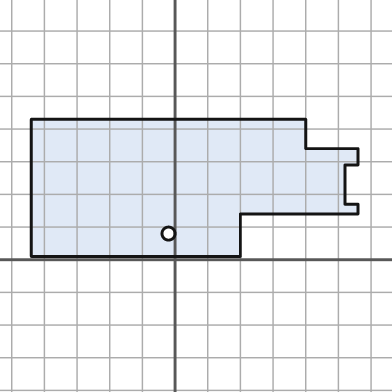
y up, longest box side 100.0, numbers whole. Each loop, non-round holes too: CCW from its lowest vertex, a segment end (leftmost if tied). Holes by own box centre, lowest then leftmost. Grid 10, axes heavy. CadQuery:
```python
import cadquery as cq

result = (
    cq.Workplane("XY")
    .moveTo(-44.0, 1.0)
    .lineTo(20.0, 1.0)
    .lineTo(20.0, 14.0)
    .lineTo(56.0, 14.0)
    .lineTo(56.0, 17.0)
    .lineTo(52.0, 17.0)
    .lineTo(52.0, 29.0)
    .lineTo(56.0, 29.0)
    .lineTo(56.0, 34.0)
    .lineTo(40.0, 34.0)
    .lineTo(40.0, 43.0)
    .lineTo(-44.0, 43.0)
    .close()
    .moveTo(-2.0, 8.0)
    .circle(2.0)
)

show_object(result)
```